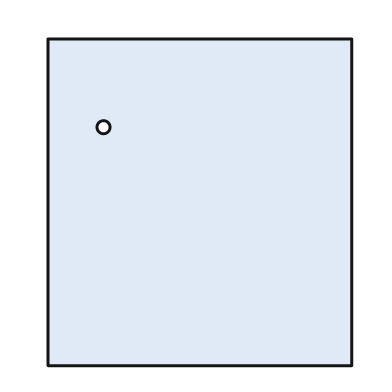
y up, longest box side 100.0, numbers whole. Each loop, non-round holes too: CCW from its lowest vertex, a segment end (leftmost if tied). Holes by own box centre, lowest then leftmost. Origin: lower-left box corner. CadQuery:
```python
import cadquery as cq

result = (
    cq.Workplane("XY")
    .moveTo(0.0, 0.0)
    .lineTo(93.0, 0.0)
    .lineTo(93.0, 100.0)
    .lineTo(0.0, 100.0)
    .close()
    .moveTo(17.0, 73.0)
    .circle(2.0)
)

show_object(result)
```